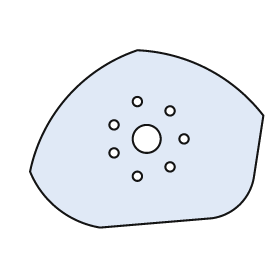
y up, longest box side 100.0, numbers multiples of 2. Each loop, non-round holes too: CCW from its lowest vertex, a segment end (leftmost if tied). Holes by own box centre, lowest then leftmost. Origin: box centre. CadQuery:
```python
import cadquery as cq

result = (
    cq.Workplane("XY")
    .moveTo(-20.0, -38.0)
    .lineTo(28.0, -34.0)
    .threePointArc((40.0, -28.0), (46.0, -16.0))
    .lineTo(50.0, 10.0)
    .threePointArc((26.0, 30.0), (-4.0, 38.0))
    .threePointArc((-34.0, 18.0), (-50.0, -14.0))
    .threePointArc((-38.0, -30.0), (-20.0, -38.0))
    .close()
    .moveTo(-4.0, -16.0)
    .circle(2.0)
    .moveTo(10.0, -12.0)
    .circle(2.0)
    .moveTo(-14.0, -6.0)
    .circle(2.0)
    .moveTo(0.0, 0.0)
    .circle(6.0)
    .moveTo(16.0, 0.0)
    .circle(2.0)
    .moveTo(-14.0, 6.0)
    .circle(2.0)
    .moveTo(10.0, 12.0)
    .circle(2.0)
    .moveTo(-4.0, 16.0)
    .circle(2.0)
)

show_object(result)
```